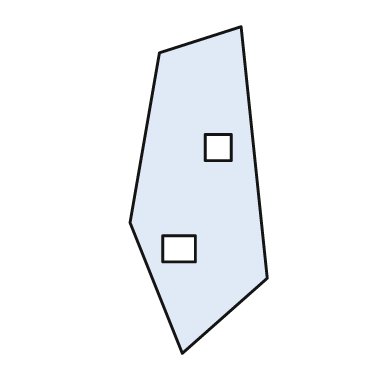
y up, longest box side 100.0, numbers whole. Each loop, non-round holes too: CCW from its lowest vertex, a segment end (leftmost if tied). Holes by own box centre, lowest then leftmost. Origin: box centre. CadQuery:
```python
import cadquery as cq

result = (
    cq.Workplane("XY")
    .moveTo(-5.0, -50.0)
    .lineTo(21.0, -27.0)
    .lineTo(13.0, 50.0)
    .lineTo(-12.0, 42.0)
    .lineTo(-21.0, -10.0)
    .close()
    .moveTo(-11.0, -22.0)
    .lineTo(-1.0, -22.0)
    .lineTo(-1.0, -14.0)
    .lineTo(-11.0, -14.0)
    .close()
    .moveTo(2.0, 9.0)
    .lineTo(10.0, 9.0)
    .lineTo(10.0, 17.0)
    .lineTo(2.0, 17.0)
    .close()
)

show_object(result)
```